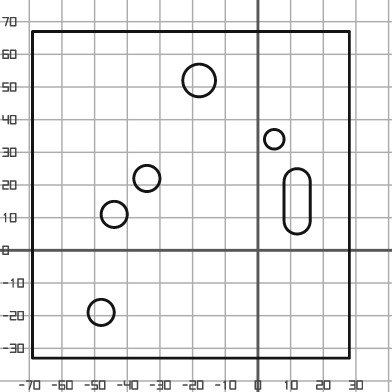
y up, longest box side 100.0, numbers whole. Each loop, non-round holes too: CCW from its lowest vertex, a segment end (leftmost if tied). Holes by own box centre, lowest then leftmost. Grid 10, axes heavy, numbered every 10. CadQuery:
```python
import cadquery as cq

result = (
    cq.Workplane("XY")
    .moveTo(-69.0, -33.0)
    .lineTo(28.0, -33.0)
    .lineTo(28.0, 67.0)
    .lineTo(-69.0, 67.0)
    .close()
    .moveTo(-48.0, -19.0)
    .circle(4.0)
    .moveTo(-44.0, 11.0)
    .circle(4.0)
    .moveTo(8.0, 9.0)
    .threePointArc((12.0, 5.0), (16.0, 9.0))
    .lineTo(16.0, 21.0)
    .threePointArc((12.0, 25.0), (8.0, 21.0))
    .close()
    .moveTo(-34.0, 22.0)
    .circle(4.0)
    .moveTo(5.0, 34.0)
    .circle(3.0)
    .moveTo(-18.0, 52.0)
    .circle(5.0)
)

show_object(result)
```